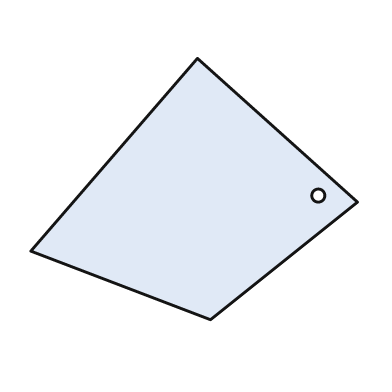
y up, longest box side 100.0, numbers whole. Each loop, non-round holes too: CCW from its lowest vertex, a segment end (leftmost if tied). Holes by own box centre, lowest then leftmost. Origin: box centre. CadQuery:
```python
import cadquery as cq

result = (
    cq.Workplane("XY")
    .moveTo(5.0, -40.0)
    .lineTo(50.0, -4.0)
    .lineTo(1.0, 40.0)
    .lineTo(-50.0, -19.0)
    .close()
    .moveTo(38.0, -2.0)
    .circle(2.0)
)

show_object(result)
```